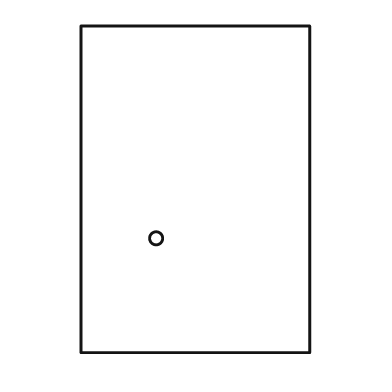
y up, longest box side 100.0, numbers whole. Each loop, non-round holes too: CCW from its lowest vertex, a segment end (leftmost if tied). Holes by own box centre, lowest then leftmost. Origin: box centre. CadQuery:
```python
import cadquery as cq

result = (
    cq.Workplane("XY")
    .moveTo(-35.0, -50.0)
    .lineTo(35.0, -50.0)
    .lineTo(35.0, 50.0)
    .lineTo(-35.0, 50.0)
    .close()
    .moveTo(-12.0, -15.0)
    .circle(2.0)
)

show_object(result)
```